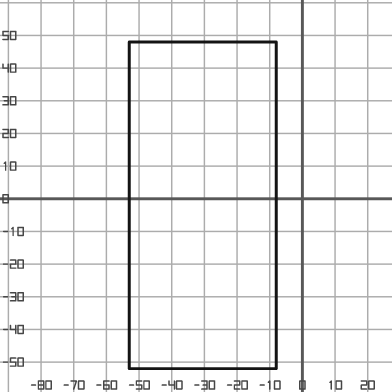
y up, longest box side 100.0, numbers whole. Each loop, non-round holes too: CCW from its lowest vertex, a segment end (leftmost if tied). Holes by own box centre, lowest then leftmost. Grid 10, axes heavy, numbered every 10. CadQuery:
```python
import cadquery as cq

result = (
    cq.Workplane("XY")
    .moveTo(-53.0, -52.0)
    .lineTo(-8.0, -52.0)
    .lineTo(-8.0, 48.0)
    .lineTo(-53.0, 48.0)
    .close()
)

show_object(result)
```